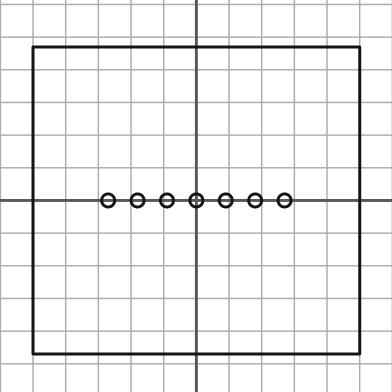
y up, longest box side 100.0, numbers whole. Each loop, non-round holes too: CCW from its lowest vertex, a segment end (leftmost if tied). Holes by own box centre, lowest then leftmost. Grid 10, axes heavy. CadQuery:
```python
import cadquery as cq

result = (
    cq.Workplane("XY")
    .moveTo(-50.0, -47.0)
    .lineTo(50.0, -47.0)
    .lineTo(50.0, 47.0)
    .lineTo(-50.0, 47.0)
    .close()
    .moveTo(-27.0, 0.0)
    .circle(2.0)
    .moveTo(-18.0, 0.0)
    .circle(2.0)
    .moveTo(-9.0, 0.0)
    .circle(2.0)
    .moveTo(0.0, 0.0)
    .circle(2.0)
    .moveTo(9.0, 0.0)
    .circle(2.0)
    .moveTo(18.0, 0.0)
    .circle(2.0)
    .moveTo(27.0, 0.0)
    .circle(2.0)
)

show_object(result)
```